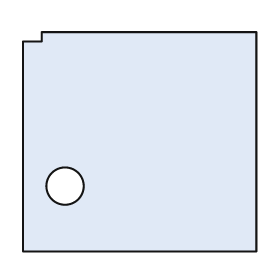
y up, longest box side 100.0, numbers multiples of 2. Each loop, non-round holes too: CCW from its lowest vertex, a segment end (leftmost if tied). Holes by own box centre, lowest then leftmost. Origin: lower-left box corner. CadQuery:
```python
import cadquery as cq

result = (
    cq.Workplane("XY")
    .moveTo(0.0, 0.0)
    .lineTo(100.0, 0.0)
    .lineTo(100.0, 94.0)
    .lineTo(8.0, 94.0)
    .lineTo(8.0, 90.0)
    .lineTo(0.0, 90.0)
    .close()
    .moveTo(18.0, 28.0)
    .circle(8.0)
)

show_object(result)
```